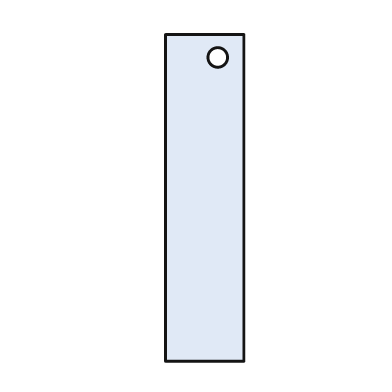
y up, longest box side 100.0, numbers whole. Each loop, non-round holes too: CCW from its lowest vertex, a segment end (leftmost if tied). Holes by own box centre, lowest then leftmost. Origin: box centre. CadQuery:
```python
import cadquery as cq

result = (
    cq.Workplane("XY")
    .moveTo(-12.0, -50.0)
    .lineTo(12.0, -50.0)
    .lineTo(12.0, 50.0)
    .lineTo(-12.0, 50.0)
    .close()
    .moveTo(4.0, 43.0)
    .circle(3.0)
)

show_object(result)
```